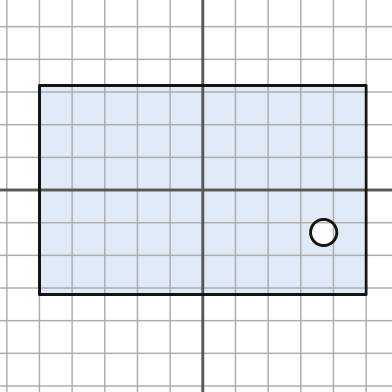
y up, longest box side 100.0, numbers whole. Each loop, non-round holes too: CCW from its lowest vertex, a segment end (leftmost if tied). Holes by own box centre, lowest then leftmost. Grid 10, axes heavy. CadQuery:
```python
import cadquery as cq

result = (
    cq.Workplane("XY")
    .moveTo(-50.0, -32.0)
    .lineTo(50.0, -32.0)
    .lineTo(50.0, 32.0)
    .lineTo(-50.0, 32.0)
    .close()
    .moveTo(37.0, -13.0)
    .circle(4.0)
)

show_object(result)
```